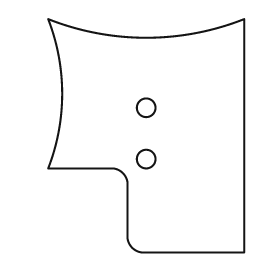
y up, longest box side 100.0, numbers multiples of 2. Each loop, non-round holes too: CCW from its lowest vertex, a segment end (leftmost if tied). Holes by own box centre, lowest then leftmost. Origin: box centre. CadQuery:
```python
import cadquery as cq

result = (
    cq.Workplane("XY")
    .moveTo(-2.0, -50.0)
    .lineTo(42.0, -50.0)
    .lineTo(42.0, 50.0)
    .threePointArc((0.0, 42.0), (-42.0, 50.0))
    .threePointArc((-36.0, 18.0), (-42.0, -14.0))
    .lineTo(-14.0, -14.0)
    .threePointArc((-10.0, -16.0), (-8.0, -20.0))
    .lineTo(-8.0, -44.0)
    .threePointArc((-6.0, -48.0), (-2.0, -50.0))
    .close()
    .moveTo(0.0, -10.0)
    .circle(4.0)
    .moveTo(0.0, 12.0)
    .circle(4.0)
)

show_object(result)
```